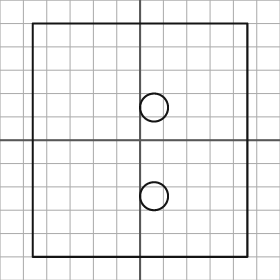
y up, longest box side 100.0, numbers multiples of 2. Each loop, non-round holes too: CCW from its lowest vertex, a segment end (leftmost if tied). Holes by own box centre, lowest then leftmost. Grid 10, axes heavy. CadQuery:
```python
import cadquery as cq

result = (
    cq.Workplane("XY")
    .moveTo(-46.0, -50.0)
    .lineTo(46.0, -50.0)
    .lineTo(46.0, 50.0)
    .lineTo(-46.0, 50.0)
    .close()
    .moveTo(6.0, -24.0)
    .circle(6.0)
    .moveTo(6.0, 14.0)
    .circle(6.0)
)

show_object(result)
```